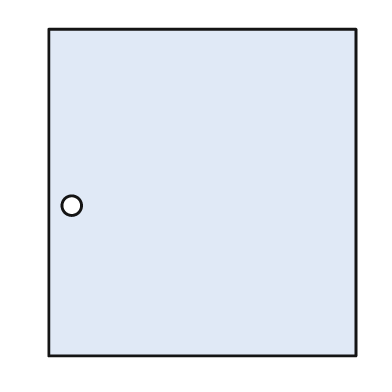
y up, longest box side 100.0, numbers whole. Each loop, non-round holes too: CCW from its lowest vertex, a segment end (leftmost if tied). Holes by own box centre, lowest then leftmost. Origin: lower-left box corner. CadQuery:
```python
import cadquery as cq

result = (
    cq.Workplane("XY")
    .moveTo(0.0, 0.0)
    .lineTo(94.0, 0.0)
    .lineTo(94.0, 100.0)
    .lineTo(0.0, 100.0)
    .close()
    .moveTo(7.0, 46.0)
    .circle(3.0)
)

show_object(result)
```